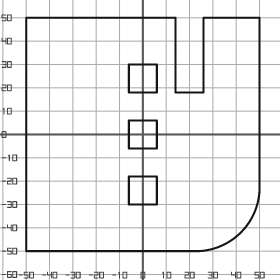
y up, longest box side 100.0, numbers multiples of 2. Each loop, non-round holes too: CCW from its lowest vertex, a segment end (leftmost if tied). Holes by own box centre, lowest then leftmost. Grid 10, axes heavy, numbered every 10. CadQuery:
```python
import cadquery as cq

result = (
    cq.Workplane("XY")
    .moveTo(-50.0, -50.0)
    .lineTo(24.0, -50.0)
    .threePointArc((42.0, -42.0), (50.0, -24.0))
    .lineTo(50.0, 50.0)
    .lineTo(26.0, 50.0)
    .lineTo(26.0, 18.0)
    .lineTo(14.0, 18.0)
    .lineTo(14.0, 50.0)
    .lineTo(-50.0, 50.0)
    .close()
    .moveTo(-6.0, -30.0)
    .lineTo(6.0, -30.0)
    .lineTo(6.0, -18.0)
    .lineTo(-6.0, -18.0)
    .close()
    .moveTo(-6.0, -6.0)
    .lineTo(6.0, -6.0)
    .lineTo(6.0, 6.0)
    .lineTo(-6.0, 6.0)
    .close()
    .moveTo(-6.0, 18.0)
    .lineTo(6.0, 18.0)
    .lineTo(6.0, 30.0)
    .lineTo(-6.0, 30.0)
    .close()
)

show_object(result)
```